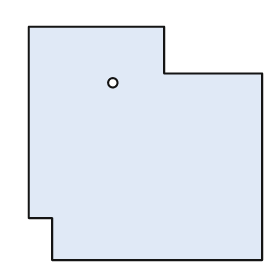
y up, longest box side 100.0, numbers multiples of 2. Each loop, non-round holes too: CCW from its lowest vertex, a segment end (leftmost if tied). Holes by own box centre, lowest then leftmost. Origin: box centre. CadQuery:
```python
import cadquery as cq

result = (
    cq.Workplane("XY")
    .moveTo(-40.0, -50.0)
    .lineTo(50.0, -50.0)
    .lineTo(50.0, 30.0)
    .lineTo(8.0, 30.0)
    .lineTo(8.0, 50.0)
    .lineTo(-50.0, 50.0)
    .lineTo(-50.0, -32.0)
    .lineTo(-40.0, -32.0)
    .close()
    .moveTo(-14.0, 26.0)
    .circle(2.0)
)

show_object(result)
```